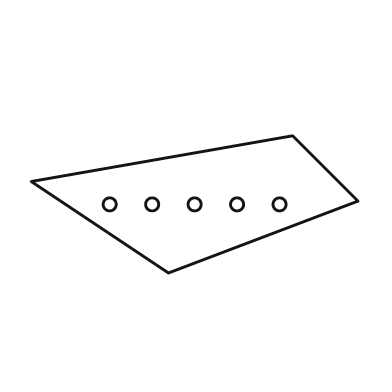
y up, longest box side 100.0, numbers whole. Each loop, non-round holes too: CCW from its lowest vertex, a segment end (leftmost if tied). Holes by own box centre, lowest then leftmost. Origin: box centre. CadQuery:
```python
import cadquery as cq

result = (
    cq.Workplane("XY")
    .moveTo(-8.0, -21.0)
    .lineTo(50.0, 1.0)
    .lineTo(30.0, 21.0)
    .lineTo(-50.0, 7.0)
    .close()
    .moveTo(-26.0, 0.0)
    .circle(2.0)
    .moveTo(-13.0, 0.0)
    .circle(2.0)
    .moveTo(0.0, 0.0)
    .circle(2.0)
    .moveTo(13.0, 0.0)
    .circle(2.0)
    .moveTo(26.0, 0.0)
    .circle(2.0)
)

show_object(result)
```